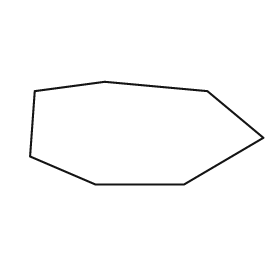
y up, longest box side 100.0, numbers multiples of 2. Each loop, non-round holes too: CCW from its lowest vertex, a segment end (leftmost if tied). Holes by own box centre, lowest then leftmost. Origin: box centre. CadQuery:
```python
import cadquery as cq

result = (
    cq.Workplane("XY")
    .moveTo(-22.0, -22.0)
    .lineTo(16.0, -22.0)
    .lineTo(50.0, -2.0)
    .lineTo(26.0, 18.0)
    .lineTo(-18.0, 22.0)
    .lineTo(-48.0, 18.0)
    .lineTo(-50.0, -10.0)
    .close()
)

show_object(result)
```